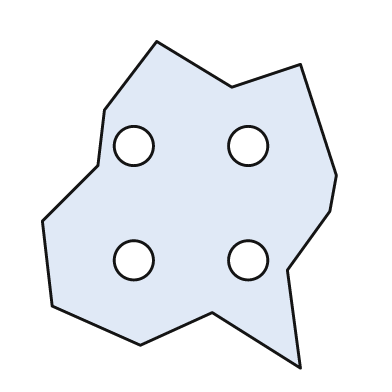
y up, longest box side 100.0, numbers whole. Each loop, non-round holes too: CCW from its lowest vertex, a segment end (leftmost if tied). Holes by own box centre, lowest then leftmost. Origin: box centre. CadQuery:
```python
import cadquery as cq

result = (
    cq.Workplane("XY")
    .moveTo(34.0, -50.0)
    .lineTo(30.0, -20.0)
    .lineTo(43.0, -2.0)
    .lineTo(45.0, 9.0)
    .lineTo(34.0, 43.0)
    .lineTo(13.0, 36.0)
    .lineTo(-10.0, 50.0)
    .lineTo(-26.0, 29.0)
    .lineTo(-28.0, 12.0)
    .lineTo(-45.0, -5.0)
    .lineTo(-42.0, -31.0)
    .lineTo(-15.0, -43.0)
    .lineTo(7.0, -33.0)
    .close()
    .moveTo(-17.0, -17.0)
    .circle(6.0)
    .moveTo(18.0, -17.0)
    .circle(6.0)
    .moveTo(-17.0, 18.0)
    .circle(6.0)
    .moveTo(18.0, 18.0)
    .circle(6.0)
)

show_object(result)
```